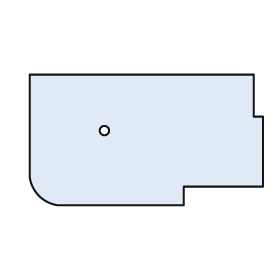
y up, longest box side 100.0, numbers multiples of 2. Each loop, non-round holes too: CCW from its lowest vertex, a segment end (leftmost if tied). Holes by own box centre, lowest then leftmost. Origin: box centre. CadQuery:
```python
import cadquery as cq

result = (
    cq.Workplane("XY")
    .moveTo(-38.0, -28.0)
    .lineTo(16.0, -28.0)
    .lineTo(16.0, -20.0)
    .lineTo(50.0, -20.0)
    .lineTo(50.0, 10.0)
    .lineTo(46.0, 10.0)
    .lineTo(46.0, 28.0)
    .lineTo(-50.0, 28.0)
    .lineTo(-50.0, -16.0)
    .threePointArc((-46.0, -24.0), (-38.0, -28.0))
    .close()
    .moveTo(-18.0, 4.0)
    .circle(2.0)
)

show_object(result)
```